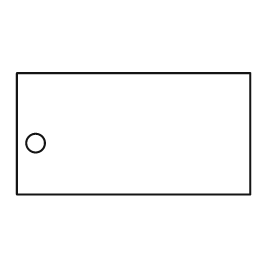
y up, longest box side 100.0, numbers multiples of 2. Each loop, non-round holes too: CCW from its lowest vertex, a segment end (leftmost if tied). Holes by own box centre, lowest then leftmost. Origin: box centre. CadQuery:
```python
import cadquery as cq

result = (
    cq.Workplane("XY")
    .moveTo(-50.0, -26.0)
    .lineTo(50.0, -26.0)
    .lineTo(50.0, 26.0)
    .lineTo(-50.0, 26.0)
    .close()
    .moveTo(-42.0, -4.0)
    .circle(4.0)
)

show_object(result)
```